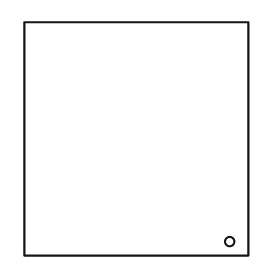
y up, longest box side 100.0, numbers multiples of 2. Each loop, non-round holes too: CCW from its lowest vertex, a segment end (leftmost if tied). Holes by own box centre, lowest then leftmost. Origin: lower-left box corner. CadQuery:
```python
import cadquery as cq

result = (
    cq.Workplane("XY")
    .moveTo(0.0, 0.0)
    .lineTo(96.0, 0.0)
    .lineTo(96.0, 100.0)
    .lineTo(0.0, 100.0)
    .close()
    .moveTo(88.0, 6.0)
    .circle(2.0)
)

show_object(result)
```